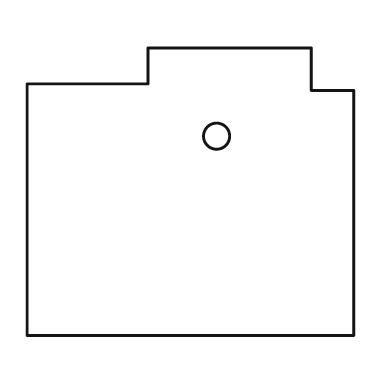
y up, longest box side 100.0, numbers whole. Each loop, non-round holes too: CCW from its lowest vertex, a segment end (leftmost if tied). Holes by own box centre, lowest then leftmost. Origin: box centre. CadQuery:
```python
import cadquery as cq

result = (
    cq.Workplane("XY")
    .moveTo(-50.0, -44.0)
    .lineTo(50.0, -44.0)
    .lineTo(50.0, 31.0)
    .lineTo(37.0, 31.0)
    .lineTo(37.0, 44.0)
    .lineTo(-13.0, 44.0)
    .lineTo(-13.0, 33.0)
    .lineTo(-50.0, 33.0)
    .close()
    .moveTo(8.0, 17.0)
    .circle(4.0)
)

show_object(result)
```